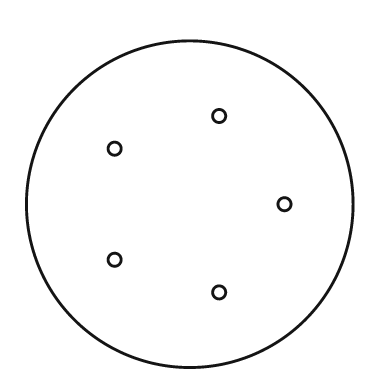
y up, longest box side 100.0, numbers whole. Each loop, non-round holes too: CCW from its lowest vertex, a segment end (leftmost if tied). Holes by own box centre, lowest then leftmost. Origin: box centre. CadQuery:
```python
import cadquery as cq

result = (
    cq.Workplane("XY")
    .moveTo(0.0, 0.0)
    .circle(50.0)
    .moveTo(9.0, -27.0)
    .circle(2.0)
    .moveTo(-23.0, -17.0)
    .circle(2.0)
    .moveTo(29.0, 0.0)
    .circle(2.0)
    .moveTo(-23.0, 17.0)
    .circle(2.0)
    .moveTo(9.0, 27.0)
    .circle(2.0)
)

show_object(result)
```